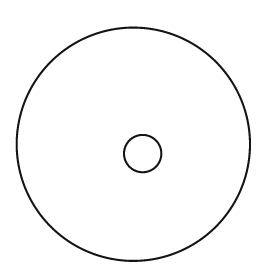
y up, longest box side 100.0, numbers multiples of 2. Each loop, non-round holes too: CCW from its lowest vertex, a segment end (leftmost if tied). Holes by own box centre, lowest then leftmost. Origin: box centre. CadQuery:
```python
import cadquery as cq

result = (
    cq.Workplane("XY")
    .moveTo(0.0, 0.0)
    .circle(50.0)
    .moveTo(4.0, -4.0)
    .circle(8.0)
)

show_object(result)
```